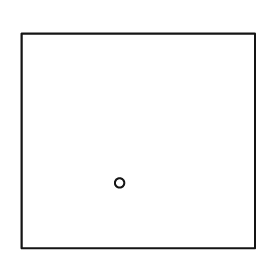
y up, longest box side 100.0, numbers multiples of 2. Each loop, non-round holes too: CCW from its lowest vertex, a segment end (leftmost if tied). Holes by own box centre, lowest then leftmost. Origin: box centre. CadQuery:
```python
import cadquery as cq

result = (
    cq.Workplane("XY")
    .moveTo(-50.0, -46.0)
    .lineTo(50.0, -46.0)
    .lineTo(50.0, 46.0)
    .lineTo(-50.0, 46.0)
    .close()
    .moveTo(-8.0, -18.0)
    .circle(2.0)
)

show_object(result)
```